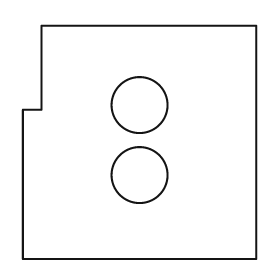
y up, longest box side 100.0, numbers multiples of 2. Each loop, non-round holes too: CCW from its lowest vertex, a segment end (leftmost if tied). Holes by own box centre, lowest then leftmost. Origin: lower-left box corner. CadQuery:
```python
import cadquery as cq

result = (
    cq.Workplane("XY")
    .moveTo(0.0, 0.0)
    .lineTo(100.0, 0.0)
    .lineTo(100.0, 100.0)
    .lineTo(8.0, 100.0)
    .lineTo(8.0, 64.0)
    .lineTo(0.0, 64.0)
    .close()
    .moveTo(50.0, 36.0)
    .circle(12.0)
    .moveTo(50.0, 66.0)
    .circle(12.0)
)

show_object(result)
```